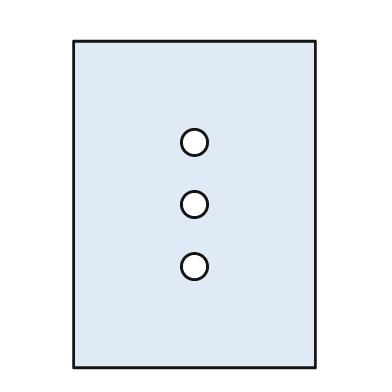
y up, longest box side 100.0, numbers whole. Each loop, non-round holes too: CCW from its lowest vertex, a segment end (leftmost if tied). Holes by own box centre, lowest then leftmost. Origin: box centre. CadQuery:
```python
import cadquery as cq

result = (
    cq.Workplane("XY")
    .moveTo(-37.0, -50.0)
    .lineTo(37.0, -50.0)
    .lineTo(37.0, 50.0)
    .lineTo(-37.0, 50.0)
    .close()
    .moveTo(0.0, -19.0)
    .circle(4.0)
    .moveTo(0.0, 0.0)
    .circle(4.0)
    .moveTo(0.0, 19.0)
    .circle(4.0)
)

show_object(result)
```